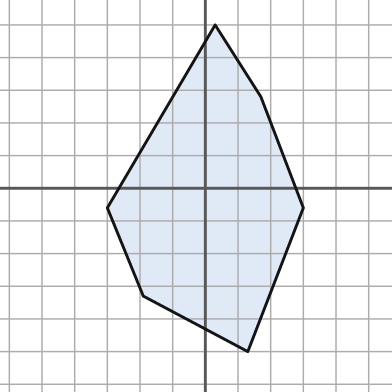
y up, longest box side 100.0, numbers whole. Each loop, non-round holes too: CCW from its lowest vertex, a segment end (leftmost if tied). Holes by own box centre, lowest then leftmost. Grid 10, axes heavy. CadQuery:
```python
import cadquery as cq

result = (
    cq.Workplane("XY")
    .moveTo(13.0, -50.0)
    .lineTo(30.0, -6.0)
    .lineTo(17.0, 28.0)
    .lineTo(3.0, 50.0)
    .lineTo(-30.0, -6.0)
    .lineTo(-19.0, -33.0)
    .close()
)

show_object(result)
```